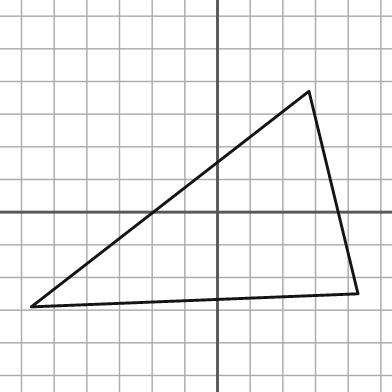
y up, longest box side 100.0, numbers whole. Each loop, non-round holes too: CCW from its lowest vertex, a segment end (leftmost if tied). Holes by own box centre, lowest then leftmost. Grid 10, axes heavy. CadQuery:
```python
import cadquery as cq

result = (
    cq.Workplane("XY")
    .moveTo(-57.0, -29.0)
    .lineTo(43.0, -25.0)
    .lineTo(28.0, 37.0)
    .close()
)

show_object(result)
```